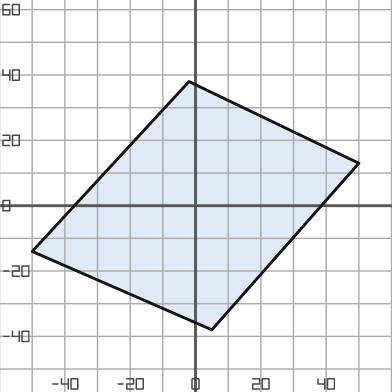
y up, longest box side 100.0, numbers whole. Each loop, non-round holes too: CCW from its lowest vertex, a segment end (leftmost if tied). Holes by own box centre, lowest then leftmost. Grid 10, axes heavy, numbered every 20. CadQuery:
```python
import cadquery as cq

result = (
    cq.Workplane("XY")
    .moveTo(5.0, -38.0)
    .lineTo(50.0, 13.0)
    .lineTo(-2.0, 38.0)
    .lineTo(-50.0, -14.0)
    .close()
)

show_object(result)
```